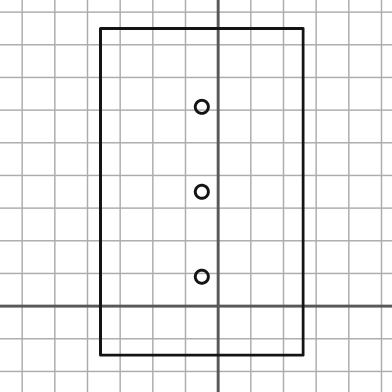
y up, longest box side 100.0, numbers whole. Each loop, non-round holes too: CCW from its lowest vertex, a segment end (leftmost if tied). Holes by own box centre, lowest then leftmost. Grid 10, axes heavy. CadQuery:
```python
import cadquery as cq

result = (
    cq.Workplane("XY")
    .moveTo(-36.0, -15.0)
    .lineTo(26.0, -15.0)
    .lineTo(26.0, 85.0)
    .lineTo(-36.0, 85.0)
    .close()
    .moveTo(-5.0, 9.0)
    .circle(2.0)
    .moveTo(-5.0, 35.0)
    .circle(2.0)
    .moveTo(-5.0, 61.0)
    .circle(2.0)
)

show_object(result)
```